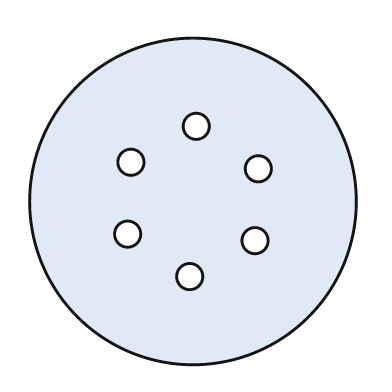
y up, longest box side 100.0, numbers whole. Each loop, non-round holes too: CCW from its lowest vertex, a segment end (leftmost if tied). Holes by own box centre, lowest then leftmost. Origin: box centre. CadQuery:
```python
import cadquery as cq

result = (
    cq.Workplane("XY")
    .moveTo(0.0, 0.0)
    .circle(50.0)
    .moveTo(-1.0, -23.0)
    .circle(4.0)
    .moveTo(19.0, -12.0)
    .circle(4.0)
    .moveTo(-20.0, -10.0)
    .circle(4.0)
    .moveTo(20.0, 10.0)
    .circle(4.0)
    .moveTo(-19.0, 12.0)
    .circle(4.0)
    .moveTo(1.0, 23.0)
    .circle(4.0)
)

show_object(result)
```